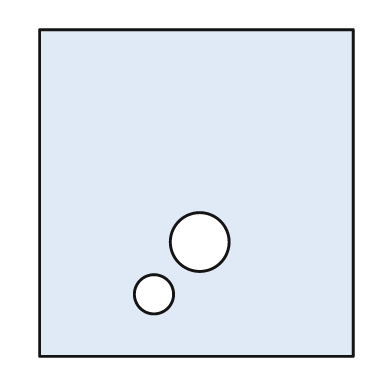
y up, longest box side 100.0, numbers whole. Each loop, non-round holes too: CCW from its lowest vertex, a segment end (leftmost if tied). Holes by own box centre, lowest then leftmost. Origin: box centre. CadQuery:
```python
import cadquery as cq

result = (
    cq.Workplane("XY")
    .moveTo(-48.0, -50.0)
    .lineTo(48.0, -50.0)
    .lineTo(48.0, 50.0)
    .lineTo(-48.0, 50.0)
    .close()
    .moveTo(-13.0, -31.0)
    .circle(6.0)
    .moveTo(1.0, -15.0)
    .circle(9.0)
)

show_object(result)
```